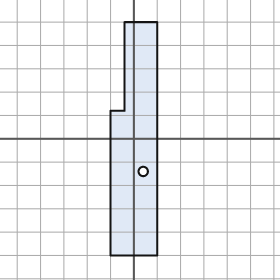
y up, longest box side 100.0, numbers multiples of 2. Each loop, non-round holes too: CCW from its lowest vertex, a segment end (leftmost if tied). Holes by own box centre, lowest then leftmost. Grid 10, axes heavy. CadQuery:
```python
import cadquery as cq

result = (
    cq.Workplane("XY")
    .moveTo(-10.0, -50.0)
    .lineTo(10.0, -50.0)
    .lineTo(10.0, 50.0)
    .lineTo(-4.0, 50.0)
    .lineTo(-4.0, 12.0)
    .lineTo(-10.0, 12.0)
    .close()
    .moveTo(4.0, -14.0)
    .circle(2.0)
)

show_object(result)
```